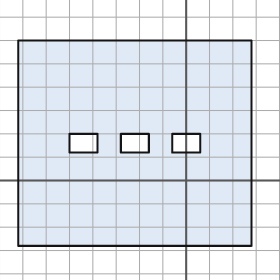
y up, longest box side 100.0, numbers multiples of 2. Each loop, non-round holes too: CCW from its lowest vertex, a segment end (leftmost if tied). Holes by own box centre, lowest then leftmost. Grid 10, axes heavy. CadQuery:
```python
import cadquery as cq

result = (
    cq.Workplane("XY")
    .moveTo(-72.0, -28.0)
    .lineTo(28.0, -28.0)
    .lineTo(28.0, 60.0)
    .lineTo(-72.0, 60.0)
    .close()
    .moveTo(-50.0, 12.0)
    .lineTo(-38.0, 12.0)
    .lineTo(-38.0, 20.0)
    .lineTo(-50.0, 20.0)
    .close()
    .moveTo(-28.0, 12.0)
    .lineTo(-16.0, 12.0)
    .lineTo(-16.0, 20.0)
    .lineTo(-28.0, 20.0)
    .close()
    .moveTo(-6.0, 12.0)
    .lineTo(6.0, 12.0)
    .lineTo(6.0, 20.0)
    .lineTo(-6.0, 20.0)
    .close()
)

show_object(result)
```